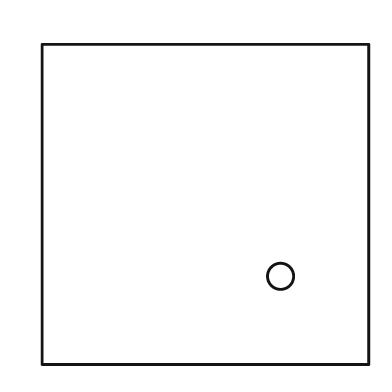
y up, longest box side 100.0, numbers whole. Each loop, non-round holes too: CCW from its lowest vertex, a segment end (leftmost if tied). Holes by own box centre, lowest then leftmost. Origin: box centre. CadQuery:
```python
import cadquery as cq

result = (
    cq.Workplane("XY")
    .moveTo(-50.0, -49.0)
    .lineTo(50.0, -49.0)
    .lineTo(50.0, 49.0)
    .lineTo(-50.0, 49.0)
    .close()
    .moveTo(23.0, -22.0)
    .circle(4.0)
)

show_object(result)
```